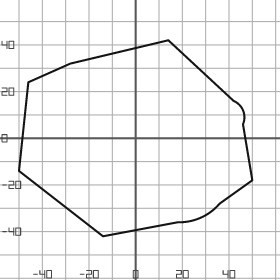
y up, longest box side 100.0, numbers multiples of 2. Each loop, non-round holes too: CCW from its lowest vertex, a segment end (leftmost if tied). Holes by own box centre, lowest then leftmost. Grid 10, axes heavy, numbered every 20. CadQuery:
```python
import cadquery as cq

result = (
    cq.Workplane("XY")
    .moveTo(-14.0, -42.0)
    .lineTo(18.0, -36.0)
    .threePointArc((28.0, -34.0), (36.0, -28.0))
    .lineTo(50.0, -18.0)
    .lineTo(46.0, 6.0)
    .threePointArc((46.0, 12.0), (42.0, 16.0))
    .lineTo(14.0, 42.0)
    .lineTo(-28.0, 32.0)
    .lineTo(-46.0, 24.0)
    .lineTo(-50.0, -14.0)
    .close()
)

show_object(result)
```